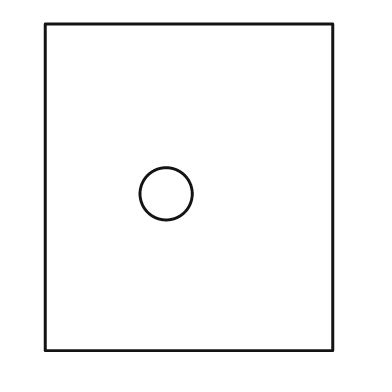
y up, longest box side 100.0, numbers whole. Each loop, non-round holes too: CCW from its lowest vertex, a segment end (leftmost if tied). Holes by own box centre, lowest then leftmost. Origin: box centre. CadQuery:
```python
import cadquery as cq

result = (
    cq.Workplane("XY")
    .moveTo(-44.0, -50.0)
    .lineTo(44.0, -50.0)
    .lineTo(44.0, 50.0)
    .lineTo(-44.0, 50.0)
    .close()
    .moveTo(-7.0, -2.0)
    .circle(8.0)
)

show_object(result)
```